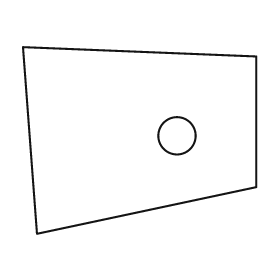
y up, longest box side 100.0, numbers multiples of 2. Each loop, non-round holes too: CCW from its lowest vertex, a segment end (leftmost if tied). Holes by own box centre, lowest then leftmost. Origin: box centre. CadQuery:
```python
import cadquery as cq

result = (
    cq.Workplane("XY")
    .moveTo(-44.0, -40.0)
    .lineTo(50.0, -20.0)
    .lineTo(50.0, 36.0)
    .lineTo(-50.0, 40.0)
    .close()
    .moveTo(16.0, 2.0)
    .circle(8.0)
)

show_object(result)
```